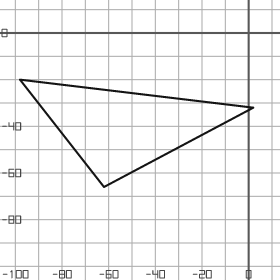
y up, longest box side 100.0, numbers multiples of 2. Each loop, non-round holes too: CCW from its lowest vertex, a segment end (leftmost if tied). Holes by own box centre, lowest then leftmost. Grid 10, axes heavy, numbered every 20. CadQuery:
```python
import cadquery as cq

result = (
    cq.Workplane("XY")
    .moveTo(-62.0, -66.0)
    .lineTo(2.0, -32.0)
    .lineTo(-98.0, -20.0)
    .close()
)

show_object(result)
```